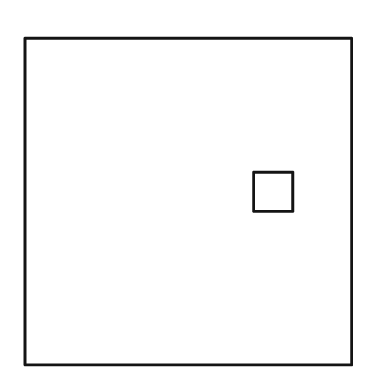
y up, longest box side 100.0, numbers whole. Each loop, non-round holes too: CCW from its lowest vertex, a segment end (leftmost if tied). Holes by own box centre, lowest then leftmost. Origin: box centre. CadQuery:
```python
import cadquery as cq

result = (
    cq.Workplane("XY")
    .moveTo(-50.0, -50.0)
    .lineTo(50.0, -50.0)
    .lineTo(50.0, 50.0)
    .lineTo(-50.0, 50.0)
    .close()
    .moveTo(20.0, -3.0)
    .lineTo(32.0, -3.0)
    .lineTo(32.0, 9.0)
    .lineTo(20.0, 9.0)
    .close()
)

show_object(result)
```